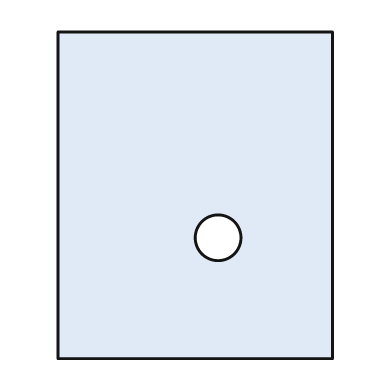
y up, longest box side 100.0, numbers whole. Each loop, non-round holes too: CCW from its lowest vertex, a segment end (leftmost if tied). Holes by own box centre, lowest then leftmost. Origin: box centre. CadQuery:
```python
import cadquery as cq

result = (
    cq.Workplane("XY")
    .moveTo(-42.0, -50.0)
    .lineTo(42.0, -50.0)
    .lineTo(42.0, 50.0)
    .lineTo(-42.0, 50.0)
    .close()
    .moveTo(7.0, -13.0)
    .circle(7.0)
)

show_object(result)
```